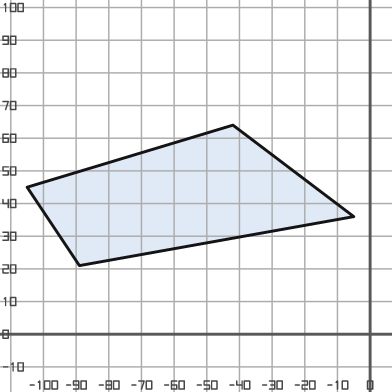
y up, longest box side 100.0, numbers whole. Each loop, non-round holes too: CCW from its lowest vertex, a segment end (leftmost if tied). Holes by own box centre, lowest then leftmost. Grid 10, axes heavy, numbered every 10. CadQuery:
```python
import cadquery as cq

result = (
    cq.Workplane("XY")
    .moveTo(-89.0, 21.0)
    .lineTo(-5.0, 36.0)
    .lineTo(-42.0, 64.0)
    .lineTo(-105.0, 45.0)
    .close()
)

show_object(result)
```